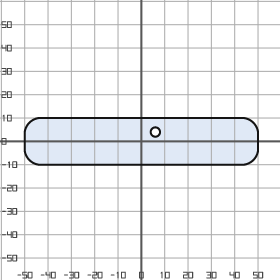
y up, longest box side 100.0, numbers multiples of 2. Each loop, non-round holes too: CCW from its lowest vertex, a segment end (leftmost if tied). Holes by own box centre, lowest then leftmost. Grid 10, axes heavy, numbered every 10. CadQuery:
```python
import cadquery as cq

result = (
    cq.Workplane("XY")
    .moveTo(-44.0, -10.0)
    .lineTo(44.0, -10.0)
    .threePointArc((48.0, -8.0), (50.0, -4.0))
    .lineTo(50.0, 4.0)
    .threePointArc((48.0, 8.0), (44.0, 10.0))
    .lineTo(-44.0, 10.0)
    .threePointArc((-48.0, 8.0), (-50.0, 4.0))
    .lineTo(-50.0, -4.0)
    .threePointArc((-48.0, -8.0), (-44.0, -10.0))
    .close()
    .moveTo(6.0, 4.0)
    .circle(2.0)
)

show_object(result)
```